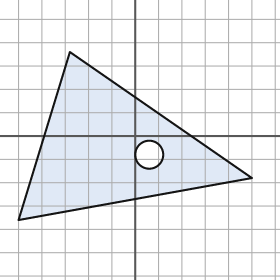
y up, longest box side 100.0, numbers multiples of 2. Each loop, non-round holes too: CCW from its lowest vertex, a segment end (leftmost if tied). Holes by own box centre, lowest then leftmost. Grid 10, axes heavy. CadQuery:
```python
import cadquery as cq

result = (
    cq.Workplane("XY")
    .moveTo(-50.0, -36.0)
    .lineTo(50.0, -18.0)
    .lineTo(-28.0, 36.0)
    .close()
    .moveTo(6.0, -8.0)
    .circle(6.0)
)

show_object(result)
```